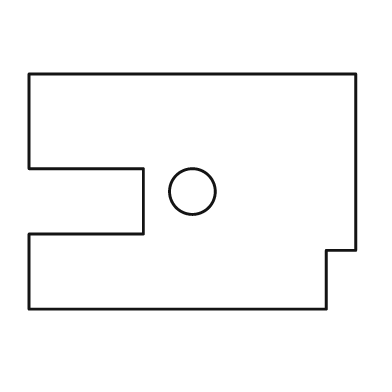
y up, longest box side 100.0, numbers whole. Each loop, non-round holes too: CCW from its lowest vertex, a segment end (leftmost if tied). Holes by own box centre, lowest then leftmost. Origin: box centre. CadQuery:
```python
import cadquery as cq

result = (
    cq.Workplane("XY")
    .moveTo(-50.0, -36.0)
    .lineTo(41.0, -36.0)
    .lineTo(41.0, -18.0)
    .lineTo(50.0, -18.0)
    .lineTo(50.0, 36.0)
    .lineTo(-50.0, 36.0)
    .lineTo(-50.0, 7.0)
    .lineTo(-15.0, 7.0)
    .lineTo(-15.0, -13.0)
    .lineTo(-50.0, -13.0)
    .close()
    .moveTo(0.0, 0.0)
    .circle(7.0)
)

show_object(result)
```